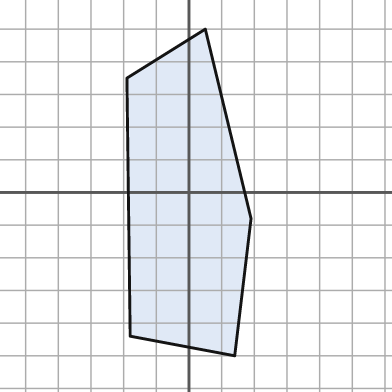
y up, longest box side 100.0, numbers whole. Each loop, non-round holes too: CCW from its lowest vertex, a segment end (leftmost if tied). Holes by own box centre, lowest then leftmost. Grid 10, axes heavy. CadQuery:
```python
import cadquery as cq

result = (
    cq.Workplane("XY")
    .moveTo(14.0, -50.0)
    .lineTo(19.0, -8.0)
    .lineTo(5.0, 50.0)
    .lineTo(-19.0, 35.0)
    .lineTo(-18.0, -44.0)
    .close()
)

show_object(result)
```